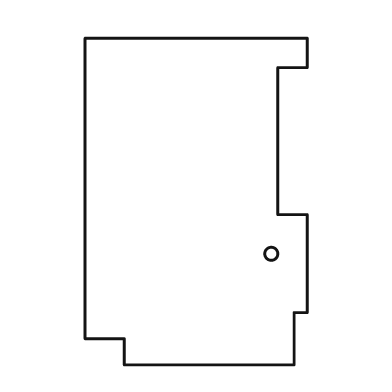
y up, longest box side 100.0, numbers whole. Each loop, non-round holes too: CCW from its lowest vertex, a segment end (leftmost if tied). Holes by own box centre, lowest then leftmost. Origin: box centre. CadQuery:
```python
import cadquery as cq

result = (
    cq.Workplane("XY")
    .moveTo(-22.0, -50.0)
    .lineTo(30.0, -50.0)
    .lineTo(30.0, -34.0)
    .lineTo(34.0, -34.0)
    .lineTo(34.0, -4.0)
    .lineTo(25.0, -4.0)
    .lineTo(25.0, 41.0)
    .lineTo(34.0, 41.0)
    .lineTo(34.0, 50.0)
    .lineTo(-34.0, 50.0)
    .lineTo(-34.0, -42.0)
    .lineTo(-22.0, -42.0)
    .close()
    .moveTo(23.0, -16.0)
    .circle(2.0)
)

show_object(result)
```